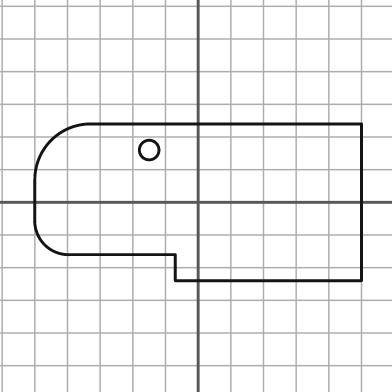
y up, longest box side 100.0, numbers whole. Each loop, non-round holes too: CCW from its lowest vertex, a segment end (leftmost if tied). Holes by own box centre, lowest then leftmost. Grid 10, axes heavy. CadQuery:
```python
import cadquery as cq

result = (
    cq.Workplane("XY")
    .moveTo(-7.0, -24.0)
    .lineTo(50.0, -24.0)
    .lineTo(50.0, 24.0)
    .lineTo(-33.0, 24.0)
    .threePointArc((-45.0, 19.0), (-50.0, 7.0))
    .lineTo(-50.0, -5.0)
    .threePointArc((-47.0, -13.0), (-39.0, -16.0))
    .lineTo(-7.0, -16.0)
    .close()
    .moveTo(-15.0, 16.0)
    .circle(3.0)
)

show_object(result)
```